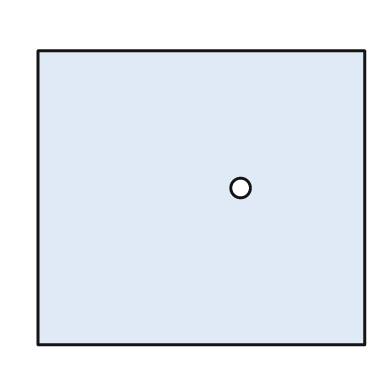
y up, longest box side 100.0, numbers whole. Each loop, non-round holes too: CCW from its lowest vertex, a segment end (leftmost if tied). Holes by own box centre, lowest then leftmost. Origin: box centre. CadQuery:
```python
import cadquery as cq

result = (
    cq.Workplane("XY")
    .moveTo(-50.0, -45.0)
    .lineTo(50.0, -45.0)
    .lineTo(50.0, 45.0)
    .lineTo(-50.0, 45.0)
    .close()
    .moveTo(12.0, 3.0)
    .circle(3.0)
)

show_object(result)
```